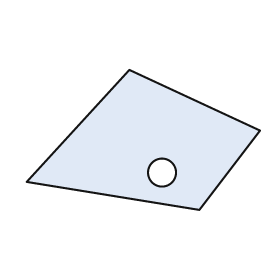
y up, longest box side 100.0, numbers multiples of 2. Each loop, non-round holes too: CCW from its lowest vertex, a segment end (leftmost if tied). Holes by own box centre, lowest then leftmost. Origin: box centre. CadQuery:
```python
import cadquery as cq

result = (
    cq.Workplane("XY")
    .moveTo(24.0, -30.0)
    .lineTo(50.0, 4.0)
    .lineTo(-6.0, 30.0)
    .lineTo(-50.0, -18.0)
    .close()
    .moveTo(8.0, -14.0)
    .circle(6.0)
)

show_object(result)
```